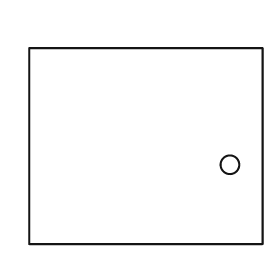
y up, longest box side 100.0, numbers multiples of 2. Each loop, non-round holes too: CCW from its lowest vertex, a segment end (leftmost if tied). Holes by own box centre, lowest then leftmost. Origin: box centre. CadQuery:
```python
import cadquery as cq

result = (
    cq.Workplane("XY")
    .moveTo(-50.0, -42.0)
    .lineTo(50.0, -42.0)
    .lineTo(50.0, 42.0)
    .lineTo(-50.0, 42.0)
    .close()
    .moveTo(36.0, -8.0)
    .circle(4.0)
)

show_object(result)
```